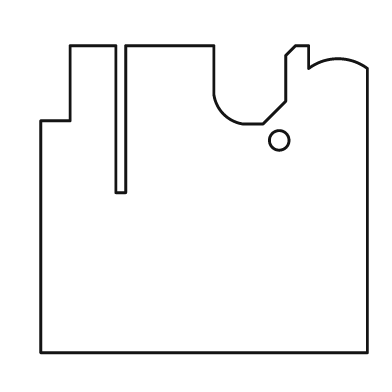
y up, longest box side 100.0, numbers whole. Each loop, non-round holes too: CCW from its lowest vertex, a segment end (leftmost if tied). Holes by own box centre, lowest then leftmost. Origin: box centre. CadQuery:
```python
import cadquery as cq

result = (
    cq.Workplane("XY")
    .moveTo(-50.0, -47.0)
    .lineTo(50.0, -47.0)
    .lineTo(50.0, 40.0)
    .threePointArc((41.0, 43.0), (32.0, 40.0))
    .lineTo(32.0, 47.0)
    .lineTo(28.0, 47.0)
    .lineTo(25.0, 44.0)
    .lineTo(25.0, 30.0)
    .lineTo(18.0, 23.0)
    .lineTo(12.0, 23.0)
    .threePointArc((6.0, 26.0), (3.0, 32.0))
    .lineTo(3.0, 47.0)
    .lineTo(-24.0, 47.0)
    .lineTo(-24.0, 2.0)
    .lineTo(-27.0, 2.0)
    .lineTo(-27.0, 47.0)
    .lineTo(-41.0, 47.0)
    .lineTo(-41.0, 24.0)
    .lineTo(-50.0, 24.0)
    .close()
    .moveTo(23.0, 18.0)
    .circle(3.0)
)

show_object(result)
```